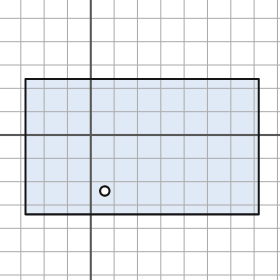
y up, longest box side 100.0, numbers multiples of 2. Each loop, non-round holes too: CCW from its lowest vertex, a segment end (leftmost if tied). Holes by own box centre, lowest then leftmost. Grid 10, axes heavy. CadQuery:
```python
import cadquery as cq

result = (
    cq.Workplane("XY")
    .moveTo(-28.0, -34.0)
    .lineTo(72.0, -34.0)
    .lineTo(72.0, 24.0)
    .lineTo(-28.0, 24.0)
    .close()
    .moveTo(6.0, -24.0)
    .circle(2.0)
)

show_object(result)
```